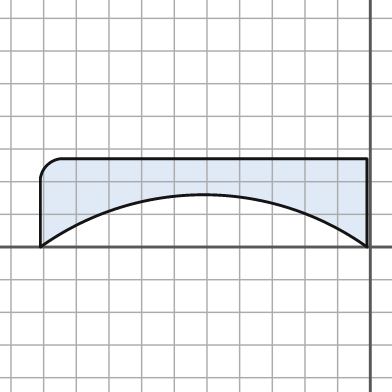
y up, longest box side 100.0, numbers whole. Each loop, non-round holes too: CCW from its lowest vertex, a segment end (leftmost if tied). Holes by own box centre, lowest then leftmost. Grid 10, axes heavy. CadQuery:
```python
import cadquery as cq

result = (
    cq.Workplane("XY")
    .moveTo(-101.0, 0.0)
    .threePointArc((-51.0, 16.0), (-1.0, 0.0))
    .lineTo(-1.0, 27.0)
    .lineTo(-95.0, 27.0)
    .threePointArc((-99.0, 25.0), (-101.0, 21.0))
    .close()
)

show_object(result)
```